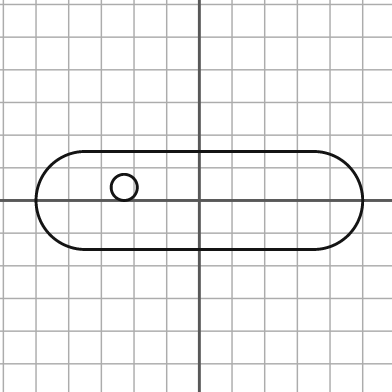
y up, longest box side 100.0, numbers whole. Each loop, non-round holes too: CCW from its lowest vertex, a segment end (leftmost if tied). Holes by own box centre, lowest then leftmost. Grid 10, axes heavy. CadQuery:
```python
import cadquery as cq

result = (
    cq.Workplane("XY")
    .moveTo(-35.0, -15.0)
    .lineTo(35.0, -15.0)
    .threePointArc((50.0, 0.0), (35.0, 15.0))
    .lineTo(-35.0, 15.0)
    .threePointArc((-50.0, 0.0), (-35.0, -15.0))
    .close()
    .moveTo(-23.0, 4.0)
    .circle(4.0)
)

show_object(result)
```